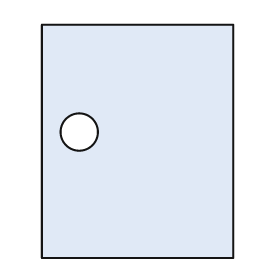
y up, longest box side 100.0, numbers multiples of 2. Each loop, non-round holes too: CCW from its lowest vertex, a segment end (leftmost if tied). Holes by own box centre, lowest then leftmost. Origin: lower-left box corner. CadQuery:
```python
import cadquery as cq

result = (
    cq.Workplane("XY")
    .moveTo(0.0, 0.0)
    .lineTo(82.0, 0.0)
    .lineTo(82.0, 100.0)
    .lineTo(0.0, 100.0)
    .close()
    .moveTo(16.0, 54.0)
    .circle(8.0)
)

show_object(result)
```